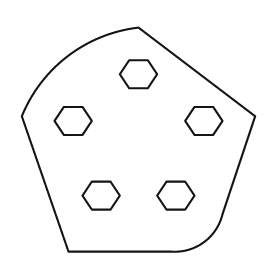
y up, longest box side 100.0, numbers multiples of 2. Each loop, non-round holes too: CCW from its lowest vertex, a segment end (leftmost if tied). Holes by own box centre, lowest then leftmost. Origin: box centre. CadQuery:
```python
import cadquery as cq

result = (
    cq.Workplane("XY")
    .moveTo(-30.0, -48.0)
    .lineTo(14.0, -48.0)
    .threePointArc((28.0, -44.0), (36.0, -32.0))
    .lineTo(50.0, 10.0)
    .lineTo(0.0, 48.0)
    .threePointArc((-30.0, 36.0), (-50.0, 10.0))
    .close()
    .moveTo(-20.0, -30.0)
    .lineTo(-12.0, -30.0)
    .lineTo(-8.0, -24.0)
    .lineTo(-12.0, -18.0)
    .lineTo(-20.0, -18.0)
    .lineTo(-24.0, -24.0)
    .close()
    .moveTo(12.0, -30.0)
    .lineTo(20.0, -30.0)
    .lineTo(24.0, -24.0)
    .lineTo(20.0, -18.0)
    .lineTo(12.0, -18.0)
    .lineTo(8.0, -24.0)
    .close()
    .moveTo(-32.0, 2.0)
    .lineTo(-24.0, 2.0)
    .lineTo(-20.0, 8.0)
    .lineTo(-24.0, 14.0)
    .lineTo(-32.0, 14.0)
    .lineTo(-36.0, 8.0)
    .close()
    .moveTo(24.0, 2.0)
    .lineTo(32.0, 2.0)
    .lineTo(36.0, 8.0)
    .lineTo(32.0, 14.0)
    .lineTo(24.0, 14.0)
    .lineTo(20.0, 8.0)
    .close()
    .moveTo(-4.0, 22.0)
    .lineTo(4.0, 22.0)
    .lineTo(8.0, 28.0)
    .lineTo(4.0, 34.0)
    .lineTo(-4.0, 34.0)
    .lineTo(-8.0, 28.0)
    .close()
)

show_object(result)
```